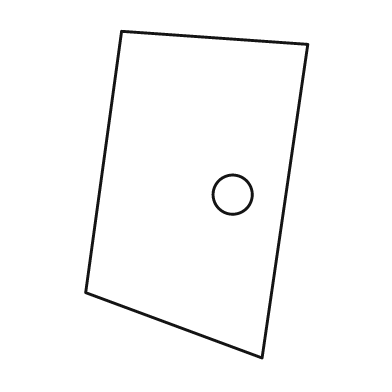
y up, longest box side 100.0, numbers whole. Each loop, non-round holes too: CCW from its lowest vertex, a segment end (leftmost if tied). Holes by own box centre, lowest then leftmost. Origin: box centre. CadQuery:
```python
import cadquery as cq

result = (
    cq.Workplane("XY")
    .moveTo(20.0, -50.0)
    .lineTo(34.0, 46.0)
    .lineTo(-23.0, 50.0)
    .lineTo(-34.0, -30.0)
    .close()
    .moveTo(11.0, 0.0)
    .circle(6.0)
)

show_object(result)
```